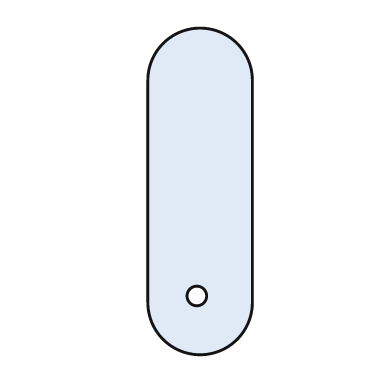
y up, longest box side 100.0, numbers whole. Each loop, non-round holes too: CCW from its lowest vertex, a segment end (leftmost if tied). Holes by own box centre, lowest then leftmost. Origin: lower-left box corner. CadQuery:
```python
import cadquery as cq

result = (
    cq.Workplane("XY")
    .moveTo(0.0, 16.0)
    .threePointArc((16.0, 0.0), (32.0, 16.0))
    .lineTo(32.0, 84.0)
    .threePointArc((16.0, 100.0), (0.0, 84.0))
    .close()
    .moveTo(15.0, 18.0)
    .circle(3.0)
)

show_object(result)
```